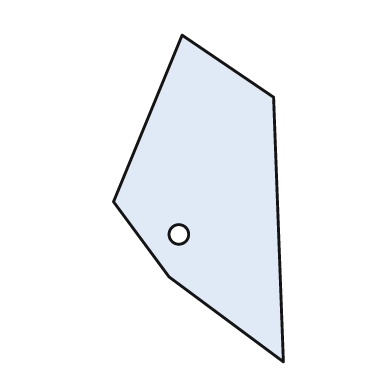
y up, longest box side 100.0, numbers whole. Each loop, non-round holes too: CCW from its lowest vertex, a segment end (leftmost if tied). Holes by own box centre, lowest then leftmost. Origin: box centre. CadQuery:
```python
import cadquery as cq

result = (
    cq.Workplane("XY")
    .moveTo(26.0, -50.0)
    .lineTo(23.0, 31.0)
    .lineTo(-5.0, 50.0)
    .lineTo(-26.0, -1.0)
    .lineTo(-9.0, -24.0)
    .close()
    .moveTo(-6.0, -11.0)
    .circle(3.0)
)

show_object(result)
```